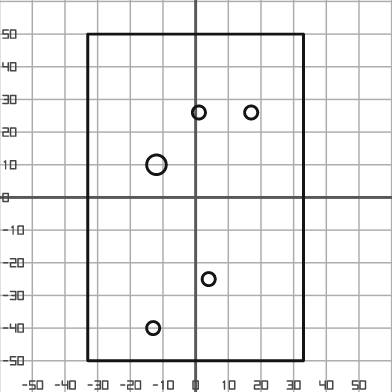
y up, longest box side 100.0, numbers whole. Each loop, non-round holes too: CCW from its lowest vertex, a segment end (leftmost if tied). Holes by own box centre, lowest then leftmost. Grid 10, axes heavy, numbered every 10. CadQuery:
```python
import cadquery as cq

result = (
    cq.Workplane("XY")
    .moveTo(-33.0, -50.0)
    .lineTo(33.0, -50.0)
    .lineTo(33.0, 50.0)
    .lineTo(-33.0, 50.0)
    .close()
    .moveTo(-13.0, -40.0)
    .circle(2.0)
    .moveTo(4.0, -25.0)
    .circle(2.0)
    .moveTo(-12.0, 10.0)
    .circle(3.0)
    .moveTo(1.0, 26.0)
    .circle(2.0)
    .moveTo(17.0, 26.0)
    .circle(2.0)
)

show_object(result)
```